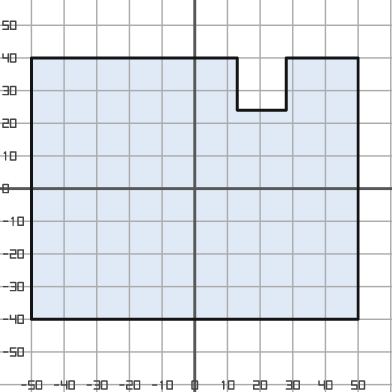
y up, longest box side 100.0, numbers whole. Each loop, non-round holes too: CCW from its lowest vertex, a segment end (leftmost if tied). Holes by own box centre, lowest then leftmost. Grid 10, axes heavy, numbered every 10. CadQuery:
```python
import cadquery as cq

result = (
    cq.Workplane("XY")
    .moveTo(-50.0, -40.0)
    .lineTo(50.0, -40.0)
    .lineTo(50.0, 40.0)
    .lineTo(28.0, 40.0)
    .lineTo(28.0, 24.0)
    .lineTo(13.0, 24.0)
    .lineTo(13.0, 40.0)
    .lineTo(-50.0, 40.0)
    .close()
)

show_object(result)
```